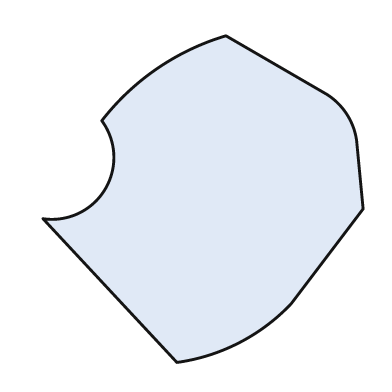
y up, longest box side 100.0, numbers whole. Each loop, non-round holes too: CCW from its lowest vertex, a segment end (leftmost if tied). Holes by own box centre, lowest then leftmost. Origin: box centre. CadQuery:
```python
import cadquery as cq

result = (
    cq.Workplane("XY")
    .moveTo(-8.0, -50.0)
    .threePointArc((11.0, -44.0), (27.0, -32.0))
    .lineTo(49.0, -3.0)
    .lineTo(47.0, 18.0)
    .threePointArc((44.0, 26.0), (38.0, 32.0))
    .lineTo(7.0, 50.0)
    .threePointArc((-14.0, 40.0), (-31.0, 24.0))
    .threePointArc((-30.0, 3.0), (-49.0, -6.0))
    .close()
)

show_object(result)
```